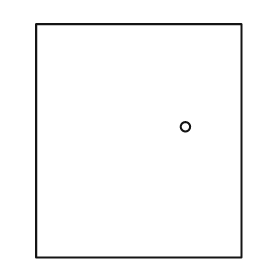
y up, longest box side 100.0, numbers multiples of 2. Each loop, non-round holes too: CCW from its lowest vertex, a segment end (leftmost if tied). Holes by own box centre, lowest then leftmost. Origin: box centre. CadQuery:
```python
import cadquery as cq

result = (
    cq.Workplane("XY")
    .moveTo(-44.0, -50.0)
    .lineTo(44.0, -50.0)
    .lineTo(44.0, 50.0)
    .lineTo(-44.0, 50.0)
    .close()
    .moveTo(20.0, 6.0)
    .circle(2.0)
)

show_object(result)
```